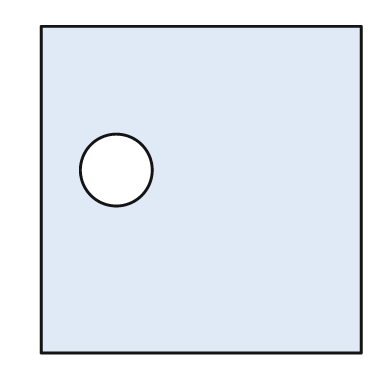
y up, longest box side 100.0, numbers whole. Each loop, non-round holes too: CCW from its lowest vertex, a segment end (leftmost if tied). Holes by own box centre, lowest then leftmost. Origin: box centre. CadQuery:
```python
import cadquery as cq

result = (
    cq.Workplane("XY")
    .moveTo(-49.0, -50.0)
    .lineTo(49.0, -50.0)
    .lineTo(49.0, 50.0)
    .lineTo(-49.0, 50.0)
    .close()
    .moveTo(-26.0, 6.0)
    .circle(11.0)
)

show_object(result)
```